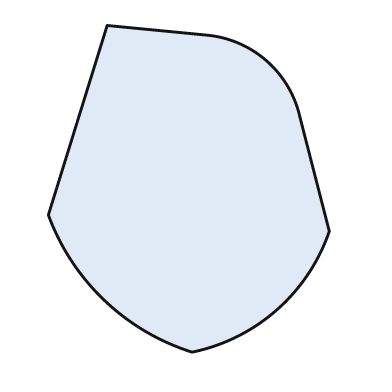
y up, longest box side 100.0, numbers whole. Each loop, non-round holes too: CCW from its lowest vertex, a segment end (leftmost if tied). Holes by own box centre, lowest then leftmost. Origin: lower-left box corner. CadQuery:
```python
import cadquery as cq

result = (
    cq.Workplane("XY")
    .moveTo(44.0, 0.0)
    .threePointArc((70.0, 13.0), (86.0, 37.0))
    .lineTo(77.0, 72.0)
    .threePointArc((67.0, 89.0), (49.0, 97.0))
    .lineTo(18.0, 100.0)
    .lineTo(0.0, 42.0)
    .threePointArc((17.0, 16.0), (44.0, 0.0))
    .close()
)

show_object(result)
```